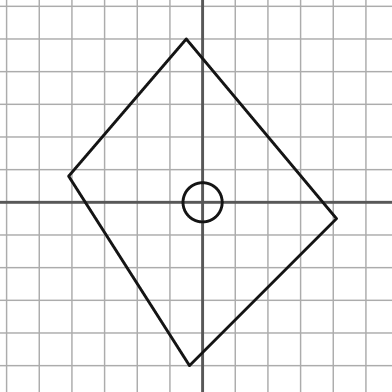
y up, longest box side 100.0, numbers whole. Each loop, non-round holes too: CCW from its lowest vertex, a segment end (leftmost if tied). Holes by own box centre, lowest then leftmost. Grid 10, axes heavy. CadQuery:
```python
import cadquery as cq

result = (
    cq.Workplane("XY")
    .moveTo(-4.0, -50.0)
    .lineTo(41.0, -5.0)
    .lineTo(-5.0, 50.0)
    .lineTo(-41.0, 8.0)
    .close()
    .moveTo(0.0, 0.0)
    .circle(6.0)
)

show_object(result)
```